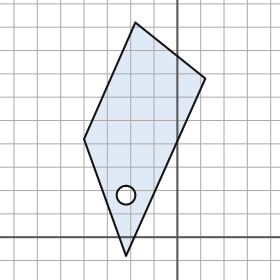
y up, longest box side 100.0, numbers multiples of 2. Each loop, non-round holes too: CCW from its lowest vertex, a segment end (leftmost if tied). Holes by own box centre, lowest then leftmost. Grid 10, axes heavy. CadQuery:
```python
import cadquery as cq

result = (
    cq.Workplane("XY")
    .moveTo(-22.0, -8.0)
    .lineTo(12.0, 68.0)
    .lineTo(-18.0, 92.0)
    .lineTo(-40.0, 42.0)
    .close()
    .moveTo(-22.0, 18.0)
    .circle(4.0)
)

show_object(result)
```